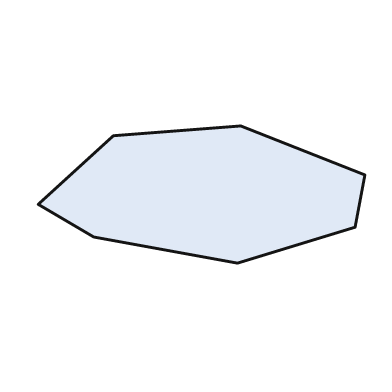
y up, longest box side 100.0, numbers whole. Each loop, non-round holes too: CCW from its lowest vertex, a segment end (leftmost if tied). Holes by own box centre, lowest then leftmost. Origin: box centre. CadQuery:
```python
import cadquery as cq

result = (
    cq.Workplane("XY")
    .moveTo(11.0, -21.0)
    .lineTo(47.0, -10.0)
    .lineTo(50.0, 6.0)
    .lineTo(12.0, 21.0)
    .lineTo(-27.0, 18.0)
    .lineTo(-50.0, -3.0)
    .lineTo(-33.0, -13.0)
    .close()
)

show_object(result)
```